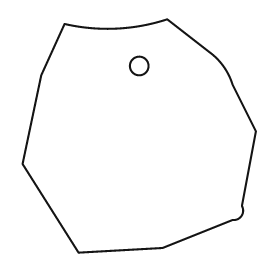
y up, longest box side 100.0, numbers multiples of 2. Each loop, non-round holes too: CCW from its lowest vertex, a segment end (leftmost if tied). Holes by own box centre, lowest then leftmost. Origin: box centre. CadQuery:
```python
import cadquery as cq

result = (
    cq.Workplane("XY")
    .moveTo(-26.0, -50.0)
    .lineTo(10.0, -48.0)
    .lineTo(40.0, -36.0)
    .threePointArc((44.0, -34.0), (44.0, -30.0))
    .lineTo(50.0, 2.0)
    .lineTo(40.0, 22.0)
    .threePointArc((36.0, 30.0), (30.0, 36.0))
    .lineTo(12.0, 50.0)
    .threePointArc((-10.0, 46.0), (-32.0, 48.0))
    .lineTo(-42.0, 26.0)
    .lineTo(-50.0, -12.0)
    .close()
    .moveTo(0.0, 30.0)
    .circle(4.0)
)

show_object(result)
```